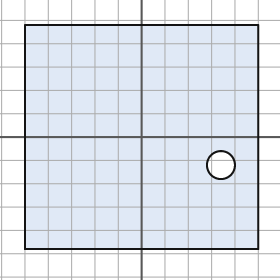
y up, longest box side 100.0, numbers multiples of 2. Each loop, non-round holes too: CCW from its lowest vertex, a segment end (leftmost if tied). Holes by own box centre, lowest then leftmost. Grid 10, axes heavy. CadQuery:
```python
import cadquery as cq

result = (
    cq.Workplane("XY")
    .moveTo(-50.0, -48.0)
    .lineTo(50.0, -48.0)
    .lineTo(50.0, 48.0)
    .lineTo(-50.0, 48.0)
    .close()
    .moveTo(34.0, -12.0)
    .circle(6.0)
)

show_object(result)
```